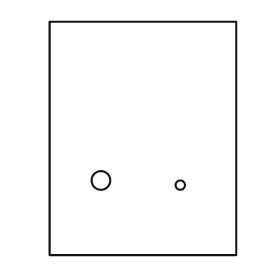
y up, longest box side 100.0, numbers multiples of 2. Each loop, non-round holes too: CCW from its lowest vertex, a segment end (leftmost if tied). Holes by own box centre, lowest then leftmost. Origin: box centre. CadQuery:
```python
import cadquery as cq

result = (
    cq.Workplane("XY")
    .moveTo(-40.0, -50.0)
    .lineTo(40.0, -50.0)
    .lineTo(40.0, 50.0)
    .lineTo(-40.0, 50.0)
    .close()
    .moveTo(16.0, -20.0)
    .circle(2.0)
    .moveTo(-18.0, -18.0)
    .circle(4.0)
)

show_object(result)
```